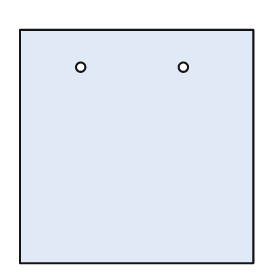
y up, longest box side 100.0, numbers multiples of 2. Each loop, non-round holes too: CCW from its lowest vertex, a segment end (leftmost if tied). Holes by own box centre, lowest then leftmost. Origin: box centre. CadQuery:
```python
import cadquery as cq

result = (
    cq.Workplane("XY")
    .moveTo(-50.0, -50.0)
    .lineTo(50.0, -50.0)
    .lineTo(50.0, 50.0)
    .lineTo(-50.0, 50.0)
    .close()
    .moveTo(-24.0, 34.0)
    .circle(2.0)
    .moveTo(20.0, 34.0)
    .circle(2.0)
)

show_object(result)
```